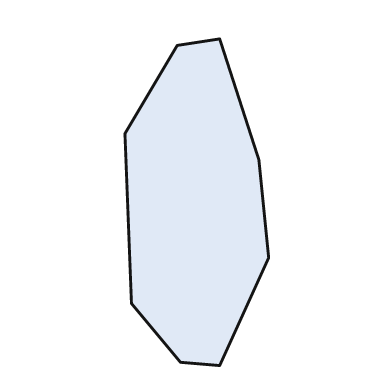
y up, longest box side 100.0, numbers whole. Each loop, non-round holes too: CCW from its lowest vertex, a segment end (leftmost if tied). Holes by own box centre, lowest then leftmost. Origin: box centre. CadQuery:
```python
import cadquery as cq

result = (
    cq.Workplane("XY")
    .moveTo(7.0, -50.0)
    .lineTo(22.0, -17.0)
    .lineTo(19.0, 13.0)
    .lineTo(7.0, 50.0)
    .lineTo(-6.0, 48.0)
    .lineTo(-22.0, 21.0)
    .lineTo(-20.0, -31.0)
    .lineTo(-5.0, -49.0)
    .close()
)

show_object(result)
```